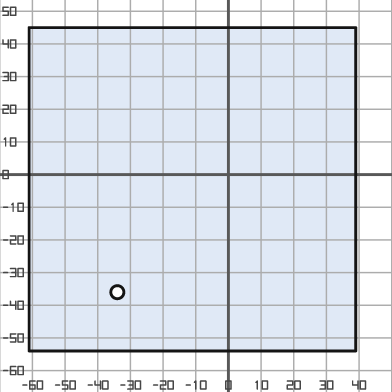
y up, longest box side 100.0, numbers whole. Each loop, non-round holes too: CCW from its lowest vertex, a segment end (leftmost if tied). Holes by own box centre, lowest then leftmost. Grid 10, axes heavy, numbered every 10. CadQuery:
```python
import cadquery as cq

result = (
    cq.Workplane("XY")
    .moveTo(-61.0, -54.0)
    .lineTo(39.0, -54.0)
    .lineTo(39.0, 45.0)
    .lineTo(-61.0, 45.0)
    .close()
    .moveTo(-34.0, -36.0)
    .circle(2.0)
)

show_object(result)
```